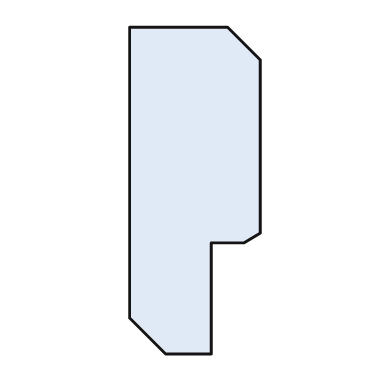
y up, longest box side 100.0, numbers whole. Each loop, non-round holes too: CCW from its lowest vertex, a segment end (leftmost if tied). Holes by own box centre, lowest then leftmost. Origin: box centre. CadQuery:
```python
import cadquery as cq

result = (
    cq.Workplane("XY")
    .moveTo(-9.0, -50.0)
    .lineTo(5.0, -50.0)
    .lineTo(5.0, -16.0)
    .lineTo(15.0, -16.0)
    .lineTo(20.0, -13.0)
    .lineTo(20.0, 40.0)
    .lineTo(10.0, 50.0)
    .lineTo(-20.0, 50.0)
    .lineTo(-20.0, -39.0)
    .close()
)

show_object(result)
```